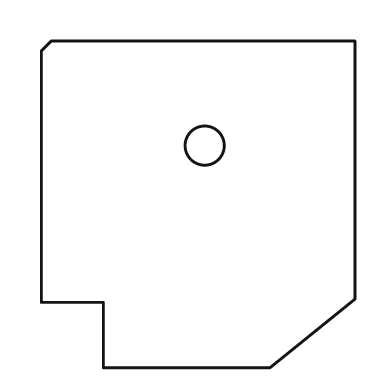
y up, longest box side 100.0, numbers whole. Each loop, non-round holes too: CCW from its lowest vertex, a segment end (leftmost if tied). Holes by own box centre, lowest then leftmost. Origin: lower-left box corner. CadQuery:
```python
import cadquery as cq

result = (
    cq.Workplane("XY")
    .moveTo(19.0, 0.0)
    .lineTo(70.0, 0.0)
    .lineTo(96.0, 21.0)
    .lineTo(96.0, 100.0)
    .lineTo(3.0, 100.0)
    .lineTo(0.0, 97.0)
    .lineTo(0.0, 20.0)
    .lineTo(19.0, 20.0)
    .close()
    .moveTo(50.0, 68.0)
    .circle(6.0)
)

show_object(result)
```